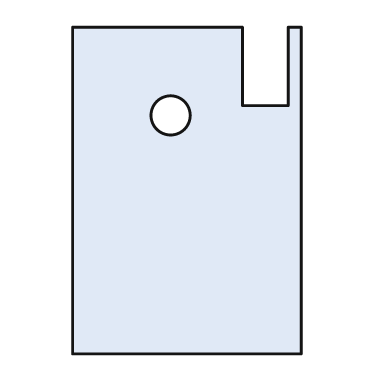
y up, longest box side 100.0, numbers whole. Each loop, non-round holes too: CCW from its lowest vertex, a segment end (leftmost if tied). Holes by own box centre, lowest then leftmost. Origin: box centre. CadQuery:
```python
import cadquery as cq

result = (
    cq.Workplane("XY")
    .moveTo(-35.0, -50.0)
    .lineTo(35.0, -50.0)
    .lineTo(35.0, 50.0)
    .lineTo(31.0, 50.0)
    .lineTo(31.0, 26.0)
    .lineTo(17.0, 26.0)
    .lineTo(17.0, 50.0)
    .lineTo(-35.0, 50.0)
    .close()
    .moveTo(-5.0, 23.0)
    .circle(6.0)
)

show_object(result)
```